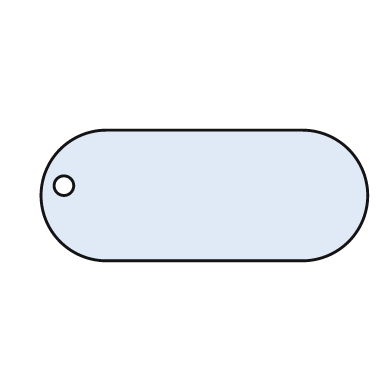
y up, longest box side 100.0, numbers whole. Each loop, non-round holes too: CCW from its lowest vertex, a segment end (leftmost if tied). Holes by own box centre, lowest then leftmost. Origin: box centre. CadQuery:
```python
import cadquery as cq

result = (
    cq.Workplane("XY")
    .moveTo(-30.0, -20.0)
    .lineTo(30.0, -20.0)
    .threePointArc((50.0, 0.0), (30.0, 20.0))
    .lineTo(-30.0, 20.0)
    .threePointArc((-50.0, 0.0), (-30.0, -20.0))
    .close()
    .moveTo(-43.0, 3.0)
    .circle(3.0)
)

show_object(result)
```